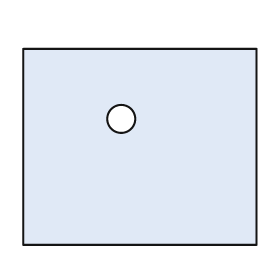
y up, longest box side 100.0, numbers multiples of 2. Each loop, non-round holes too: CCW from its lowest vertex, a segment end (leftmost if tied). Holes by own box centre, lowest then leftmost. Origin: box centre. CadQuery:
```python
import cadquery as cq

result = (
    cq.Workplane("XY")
    .moveTo(-50.0, -42.0)
    .lineTo(50.0, -42.0)
    .lineTo(50.0, 42.0)
    .lineTo(-50.0, 42.0)
    .close()
    .moveTo(-8.0, 12.0)
    .circle(6.0)
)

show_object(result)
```